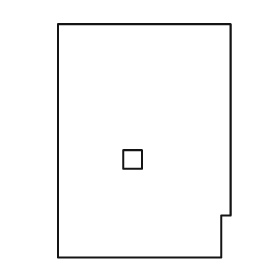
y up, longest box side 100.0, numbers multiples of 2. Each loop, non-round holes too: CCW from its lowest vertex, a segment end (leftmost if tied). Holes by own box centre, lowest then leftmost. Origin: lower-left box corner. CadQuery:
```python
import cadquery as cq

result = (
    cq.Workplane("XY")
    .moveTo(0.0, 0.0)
    .lineTo(70.0, 0.0)
    .lineTo(70.0, 18.0)
    .lineTo(74.0, 18.0)
    .lineTo(74.0, 100.0)
    .lineTo(0.0, 100.0)
    .close()
    .moveTo(28.0, 38.0)
    .lineTo(36.0, 38.0)
    .lineTo(36.0, 46.0)
    .lineTo(28.0, 46.0)
    .close()
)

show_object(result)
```